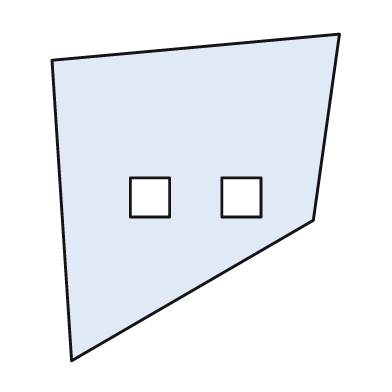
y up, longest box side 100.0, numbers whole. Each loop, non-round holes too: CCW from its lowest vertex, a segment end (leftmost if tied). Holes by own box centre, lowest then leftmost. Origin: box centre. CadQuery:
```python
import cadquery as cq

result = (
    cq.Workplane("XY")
    .moveTo(-38.0, -50.0)
    .lineTo(36.0, -7.0)
    .lineTo(44.0, 50.0)
    .lineTo(-44.0, 42.0)
    .close()
    .moveTo(-20.0, -6.0)
    .lineTo(-8.0, -6.0)
    .lineTo(-8.0, 6.0)
    .lineTo(-20.0, 6.0)
    .close()
    .moveTo(8.0, -6.0)
    .lineTo(20.0, -6.0)
    .lineTo(20.0, 6.0)
    .lineTo(8.0, 6.0)
    .close()
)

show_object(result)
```